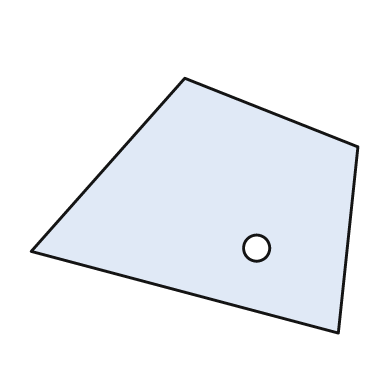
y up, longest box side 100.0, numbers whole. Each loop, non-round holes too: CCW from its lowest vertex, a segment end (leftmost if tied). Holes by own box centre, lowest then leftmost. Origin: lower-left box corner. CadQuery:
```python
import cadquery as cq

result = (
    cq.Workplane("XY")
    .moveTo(94.0, 0.0)
    .lineTo(100.0, 57.0)
    .lineTo(47.0, 78.0)
    .lineTo(0.0, 25.0)
    .close()
    .moveTo(69.0, 26.0)
    .circle(4.0)
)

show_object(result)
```